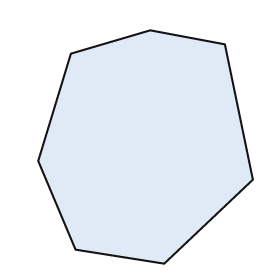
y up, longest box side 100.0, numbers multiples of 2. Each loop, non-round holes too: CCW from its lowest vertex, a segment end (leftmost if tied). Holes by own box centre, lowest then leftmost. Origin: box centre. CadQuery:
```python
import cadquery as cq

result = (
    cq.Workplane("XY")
    .moveTo(8.0, -50.0)
    .lineTo(46.0, -14.0)
    .lineTo(34.0, 44.0)
    .lineTo(2.0, 50.0)
    .lineTo(-32.0, 40.0)
    .lineTo(-46.0, -6.0)
    .lineTo(-30.0, -44.0)
    .close()
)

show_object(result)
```